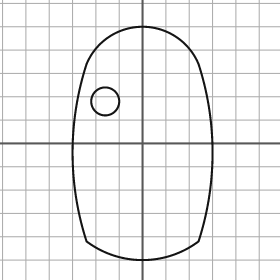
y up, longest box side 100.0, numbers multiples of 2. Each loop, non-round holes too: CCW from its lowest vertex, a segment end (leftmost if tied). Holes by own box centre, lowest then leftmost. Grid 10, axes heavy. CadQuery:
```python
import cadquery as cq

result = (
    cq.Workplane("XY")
    .moveTo(-24.0, -42.0)
    .threePointArc((0.0, -50.0), (24.0, -42.0))
    .threePointArc((30.0, -4.0), (24.0, 34.0))
    .threePointArc((0.0, 50.0), (-24.0, 34.0))
    .threePointArc((-30.0, -4.0), (-24.0, -42.0))
    .close()
    .moveTo(-16.0, 18.0)
    .circle(6.0)
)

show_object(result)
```